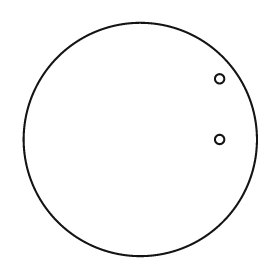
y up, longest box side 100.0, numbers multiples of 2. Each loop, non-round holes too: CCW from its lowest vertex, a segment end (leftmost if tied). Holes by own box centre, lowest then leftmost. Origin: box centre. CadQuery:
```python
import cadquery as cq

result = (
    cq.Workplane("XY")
    .moveTo(0.0, 0.0)
    .circle(50.0)
    .moveTo(34.0, 0.0)
    .circle(2.0)
    .moveTo(34.0, 26.0)
    .circle(2.0)
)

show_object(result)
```